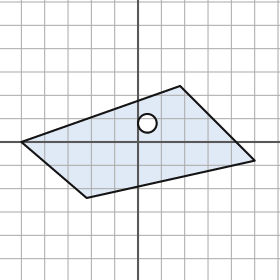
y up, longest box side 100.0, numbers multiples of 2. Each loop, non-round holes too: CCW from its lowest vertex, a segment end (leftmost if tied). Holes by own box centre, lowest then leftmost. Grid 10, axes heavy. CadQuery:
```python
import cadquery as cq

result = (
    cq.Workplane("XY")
    .moveTo(-22.0, -24.0)
    .lineTo(50.0, -8.0)
    .lineTo(18.0, 24.0)
    .lineTo(-50.0, 0.0)
    .close()
    .moveTo(4.0, 8.0)
    .circle(4.0)
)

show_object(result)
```